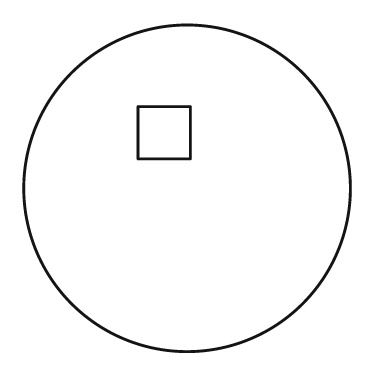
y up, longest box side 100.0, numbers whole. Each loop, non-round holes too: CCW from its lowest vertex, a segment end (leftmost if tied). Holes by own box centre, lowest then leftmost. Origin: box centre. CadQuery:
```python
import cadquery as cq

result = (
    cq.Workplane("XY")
    .moveTo(0.0, 0.0)
    .circle(50.0)
    .moveTo(-15.0, 9.0)
    .lineTo(1.0, 9.0)
    .lineTo(1.0, 25.0)
    .lineTo(-15.0, 25.0)
    .close()
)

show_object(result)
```